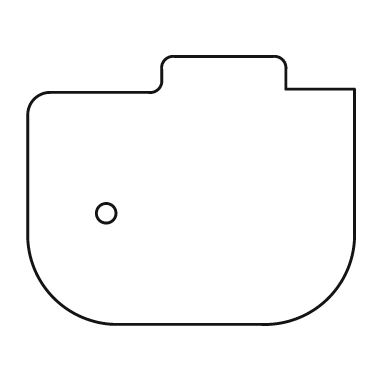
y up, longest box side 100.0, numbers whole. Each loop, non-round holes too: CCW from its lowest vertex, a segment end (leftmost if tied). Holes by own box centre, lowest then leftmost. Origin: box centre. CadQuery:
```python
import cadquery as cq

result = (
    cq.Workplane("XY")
    .moveTo(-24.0, -41.0)
    .lineTo(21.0, -41.0)
    .threePointArc((42.0, -33.0), (50.0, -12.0))
    .lineTo(50.0, 31.0)
    .lineTo(29.0, 31.0)
    .lineTo(29.0, 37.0)
    .threePointArc((28.0, 40.0), (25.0, 41.0))
    .lineTo(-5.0, 41.0)
    .threePointArc((-8.0, 40.0), (-9.0, 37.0))
    .lineTo(-9.0, 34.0)
    .threePointArc((-10.0, 31.0), (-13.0, 30.0))
    .lineTo(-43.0, 30.0)
    .threePointArc((-48.0, 28.0), (-50.0, 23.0))
    .lineTo(-50.0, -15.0)
    .threePointArc((-42.0, -33.0), (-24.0, -41.0))
    .close()
    .moveTo(-26.0, -7.0)
    .circle(3.0)
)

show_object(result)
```